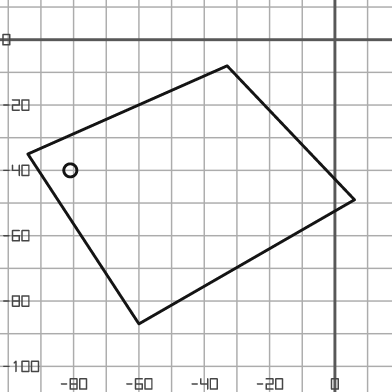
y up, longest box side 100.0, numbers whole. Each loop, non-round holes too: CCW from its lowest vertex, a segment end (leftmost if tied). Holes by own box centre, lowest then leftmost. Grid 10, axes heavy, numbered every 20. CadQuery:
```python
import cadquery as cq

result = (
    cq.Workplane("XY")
    .moveTo(-60.0, -87.0)
    .lineTo(6.0, -49.0)
    .lineTo(-33.0, -8.0)
    .lineTo(-94.0, -35.0)
    .close()
    .moveTo(-81.0, -40.0)
    .circle(2.0)
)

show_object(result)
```